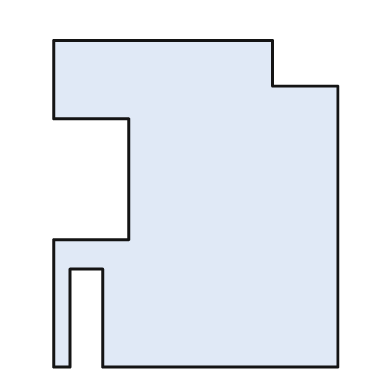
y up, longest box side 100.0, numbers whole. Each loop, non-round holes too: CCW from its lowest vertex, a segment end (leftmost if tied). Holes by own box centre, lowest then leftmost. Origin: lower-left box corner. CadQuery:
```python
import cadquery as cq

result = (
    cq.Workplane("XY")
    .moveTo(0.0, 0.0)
    .lineTo(5.0, 0.0)
    .lineTo(5.0, 30.0)
    .lineTo(15.0, 30.0)
    .lineTo(15.0, 0.0)
    .lineTo(87.0, 0.0)
    .lineTo(87.0, 86.0)
    .lineTo(67.0, 86.0)
    .lineTo(67.0, 100.0)
    .lineTo(0.0, 100.0)
    .lineTo(0.0, 76.0)
    .lineTo(23.0, 76.0)
    .lineTo(23.0, 39.0)
    .lineTo(0.0, 39.0)
    .close()
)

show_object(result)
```